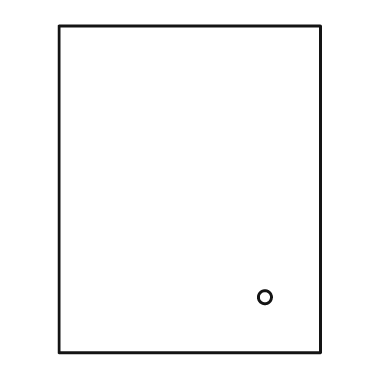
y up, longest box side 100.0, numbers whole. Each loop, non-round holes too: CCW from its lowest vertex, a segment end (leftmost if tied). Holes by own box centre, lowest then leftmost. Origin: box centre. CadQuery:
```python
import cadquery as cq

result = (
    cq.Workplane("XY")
    .moveTo(-40.0, -50.0)
    .lineTo(40.0, -50.0)
    .lineTo(40.0, 50.0)
    .lineTo(-40.0, 50.0)
    .close()
    .moveTo(23.0, -33.0)
    .circle(2.0)
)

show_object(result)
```